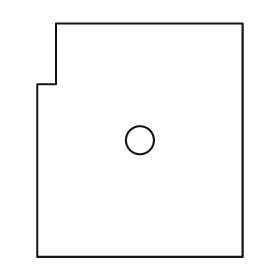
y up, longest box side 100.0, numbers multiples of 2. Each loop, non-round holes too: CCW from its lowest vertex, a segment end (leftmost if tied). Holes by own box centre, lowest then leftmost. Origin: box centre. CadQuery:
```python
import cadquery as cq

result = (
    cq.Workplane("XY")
    .moveTo(-44.0, -50.0)
    .lineTo(44.0, -50.0)
    .lineTo(44.0, 50.0)
    .lineTo(-36.0, 50.0)
    .lineTo(-36.0, 24.0)
    .lineTo(-44.0, 24.0)
    .close()
    .moveTo(0.0, 0.0)
    .circle(6.0)
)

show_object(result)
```